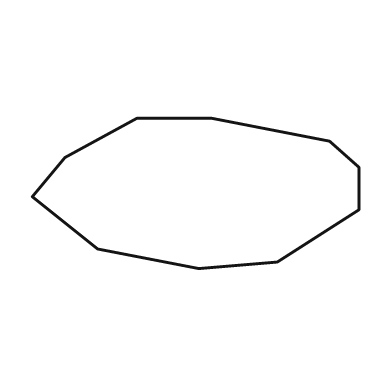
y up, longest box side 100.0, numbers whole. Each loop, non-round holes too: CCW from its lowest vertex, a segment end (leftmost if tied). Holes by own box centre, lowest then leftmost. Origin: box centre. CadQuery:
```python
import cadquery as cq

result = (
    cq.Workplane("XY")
    .moveTo(1.0, -23.0)
    .lineTo(25.0, -21.0)
    .lineTo(50.0, -5.0)
    .lineTo(50.0, 8.0)
    .lineTo(41.0, 16.0)
    .lineTo(5.0, 23.0)
    .lineTo(-18.0, 23.0)
    .lineTo(-40.0, 11.0)
    .lineTo(-50.0, -1.0)
    .lineTo(-30.0, -17.0)
    .close()
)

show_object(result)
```